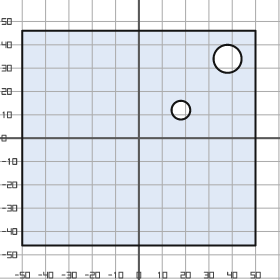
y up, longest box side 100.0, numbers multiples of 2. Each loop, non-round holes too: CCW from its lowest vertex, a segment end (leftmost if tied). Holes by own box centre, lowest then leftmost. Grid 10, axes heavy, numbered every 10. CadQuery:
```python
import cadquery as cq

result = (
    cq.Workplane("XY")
    .moveTo(-50.0, -46.0)
    .lineTo(50.0, -46.0)
    .lineTo(50.0, 46.0)
    .lineTo(-50.0, 46.0)
    .close()
    .moveTo(18.0, 12.0)
    .circle(4.0)
    .moveTo(38.0, 34.0)
    .circle(6.0)
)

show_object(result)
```